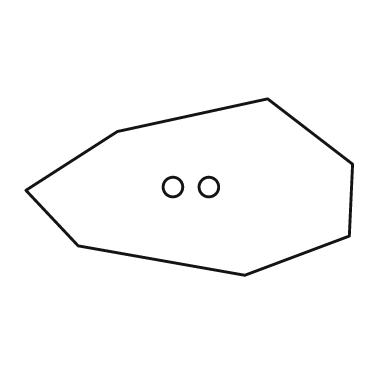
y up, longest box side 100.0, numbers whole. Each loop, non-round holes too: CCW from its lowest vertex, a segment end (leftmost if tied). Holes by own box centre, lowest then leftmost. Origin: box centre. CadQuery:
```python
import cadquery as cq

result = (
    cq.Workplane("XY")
    .moveTo(17.0, -27.0)
    .lineTo(49.0, -15.0)
    .lineTo(50.0, 7.0)
    .lineTo(24.0, 27.0)
    .lineTo(-22.0, 17.0)
    .lineTo(-50.0, -1.0)
    .lineTo(-34.0, -18.0)
    .close()
    .moveTo(-5.0, 0.0)
    .circle(3.0)
    .moveTo(6.0, 0.0)
    .circle(3.0)
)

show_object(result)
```